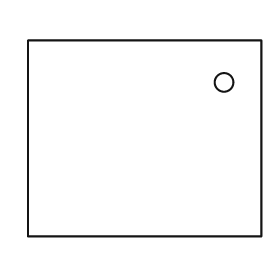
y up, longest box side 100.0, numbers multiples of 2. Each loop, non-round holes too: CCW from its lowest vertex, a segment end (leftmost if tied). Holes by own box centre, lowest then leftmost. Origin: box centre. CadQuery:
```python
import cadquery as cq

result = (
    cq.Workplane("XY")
    .moveTo(-50.0, -42.0)
    .lineTo(50.0, -42.0)
    .lineTo(50.0, 42.0)
    .lineTo(-50.0, 42.0)
    .close()
    .moveTo(34.0, 24.0)
    .circle(4.0)
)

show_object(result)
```